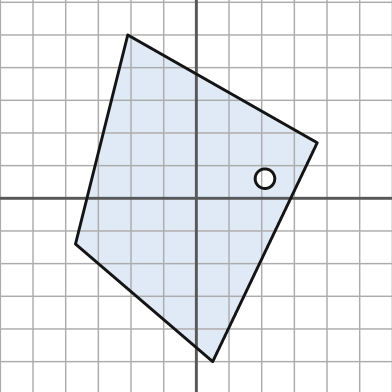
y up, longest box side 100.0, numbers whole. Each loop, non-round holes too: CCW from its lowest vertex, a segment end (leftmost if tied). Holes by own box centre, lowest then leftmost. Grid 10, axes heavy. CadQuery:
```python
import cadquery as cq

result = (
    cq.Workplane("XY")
    .moveTo(5.0, -50.0)
    .lineTo(37.0, 17.0)
    .lineTo(-21.0, 50.0)
    .lineTo(-37.0, -14.0)
    .close()
    .moveTo(21.0, 6.0)
    .circle(3.0)
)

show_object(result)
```